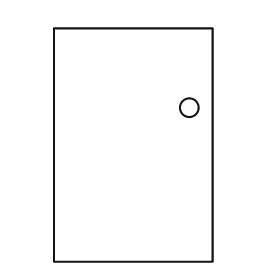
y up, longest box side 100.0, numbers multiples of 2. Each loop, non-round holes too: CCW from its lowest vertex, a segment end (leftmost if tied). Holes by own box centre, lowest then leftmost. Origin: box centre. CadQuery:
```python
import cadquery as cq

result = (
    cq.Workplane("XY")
    .moveTo(-34.0, -50.0)
    .lineTo(34.0, -50.0)
    .lineTo(34.0, 50.0)
    .lineTo(-34.0, 50.0)
    .close()
    .moveTo(24.0, 16.0)
    .circle(4.0)
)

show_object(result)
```